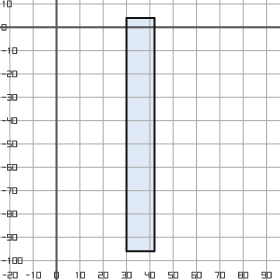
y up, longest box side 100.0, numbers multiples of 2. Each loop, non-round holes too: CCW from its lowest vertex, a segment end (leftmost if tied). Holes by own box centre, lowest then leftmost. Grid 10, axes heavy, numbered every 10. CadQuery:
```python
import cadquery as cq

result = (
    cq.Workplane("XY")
    .moveTo(30.0, -96.0)
    .lineTo(42.0, -96.0)
    .lineTo(42.0, 4.0)
    .lineTo(30.0, 4.0)
    .close()
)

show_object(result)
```